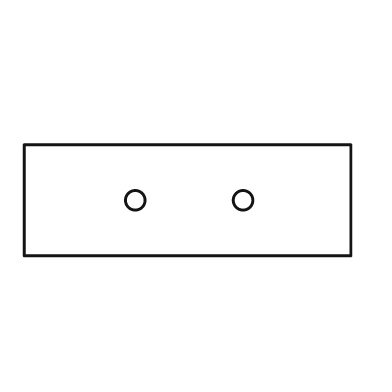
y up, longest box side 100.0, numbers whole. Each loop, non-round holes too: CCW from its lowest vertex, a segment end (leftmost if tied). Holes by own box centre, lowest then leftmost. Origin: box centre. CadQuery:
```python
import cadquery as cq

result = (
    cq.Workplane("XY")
    .moveTo(-50.0, -17.0)
    .lineTo(50.0, -17.0)
    .lineTo(50.0, 17.0)
    .lineTo(-50.0, 17.0)
    .close()
    .moveTo(-16.0, 0.0)
    .circle(3.0)
    .moveTo(17.0, 0.0)
    .circle(3.0)
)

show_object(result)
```